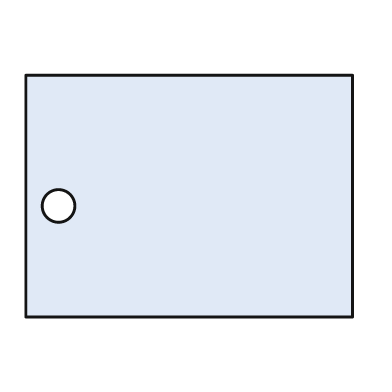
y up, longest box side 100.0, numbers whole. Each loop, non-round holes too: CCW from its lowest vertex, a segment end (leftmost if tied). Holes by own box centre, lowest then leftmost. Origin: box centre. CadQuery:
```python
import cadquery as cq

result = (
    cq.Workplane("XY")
    .moveTo(-50.0, -37.0)
    .lineTo(50.0, -37.0)
    .lineTo(50.0, 37.0)
    .lineTo(-50.0, 37.0)
    .close()
    .moveTo(-40.0, -3.0)
    .circle(5.0)
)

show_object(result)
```